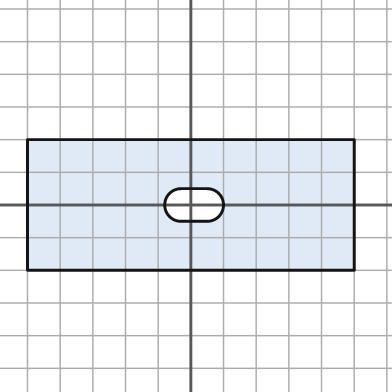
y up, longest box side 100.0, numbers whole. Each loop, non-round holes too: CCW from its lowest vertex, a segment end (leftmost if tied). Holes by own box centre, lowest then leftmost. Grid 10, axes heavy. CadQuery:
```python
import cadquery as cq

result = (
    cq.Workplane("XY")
    .moveTo(-50.0, -20.0)
    .lineTo(50.0, -20.0)
    .lineTo(50.0, 20.0)
    .lineTo(-50.0, 20.0)
    .close()
    .moveTo(-3.0, -5.0)
    .lineTo(5.0, -5.0)
    .threePointArc((10.0, 0.0), (5.0, 5.0))
    .lineTo(-3.0, 5.0)
    .threePointArc((-8.0, 0.0), (-3.0, -5.0))
    .close()
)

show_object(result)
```